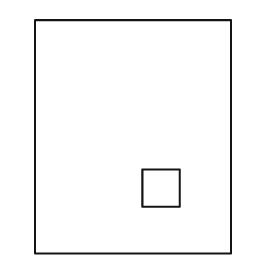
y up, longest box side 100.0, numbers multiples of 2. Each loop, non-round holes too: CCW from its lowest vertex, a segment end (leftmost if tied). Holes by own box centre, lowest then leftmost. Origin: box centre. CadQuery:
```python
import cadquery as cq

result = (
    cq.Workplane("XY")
    .moveTo(-42.0, -50.0)
    .lineTo(42.0, -50.0)
    .lineTo(42.0, 50.0)
    .lineTo(-42.0, 50.0)
    .close()
    .moveTo(4.0, -30.0)
    .lineTo(20.0, -30.0)
    .lineTo(20.0, -14.0)
    .lineTo(4.0, -14.0)
    .close()
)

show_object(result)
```